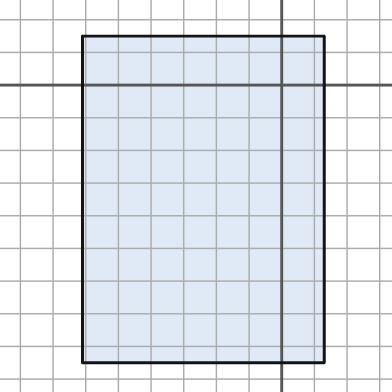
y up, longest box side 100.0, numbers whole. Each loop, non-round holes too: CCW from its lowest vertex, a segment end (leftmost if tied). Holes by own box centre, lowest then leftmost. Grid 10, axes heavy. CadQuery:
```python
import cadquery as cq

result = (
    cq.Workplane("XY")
    .moveTo(-61.0, -85.0)
    .lineTo(13.0, -85.0)
    .lineTo(13.0, 15.0)
    .lineTo(-61.0, 15.0)
    .close()
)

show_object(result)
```